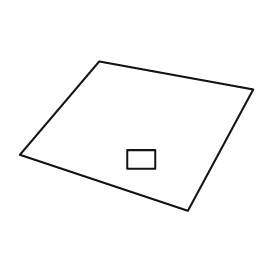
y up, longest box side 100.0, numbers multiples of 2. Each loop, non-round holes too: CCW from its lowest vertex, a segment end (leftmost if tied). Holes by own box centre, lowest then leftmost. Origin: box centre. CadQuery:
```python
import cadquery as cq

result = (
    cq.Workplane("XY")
    .moveTo(22.0, -32.0)
    .lineTo(50.0, 20.0)
    .lineTo(-16.0, 32.0)
    .lineTo(-50.0, -8.0)
    .close()
    .moveTo(-4.0, -14.0)
    .lineTo(8.0, -14.0)
    .lineTo(8.0, -6.0)
    .lineTo(-4.0, -6.0)
    .close()
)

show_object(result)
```